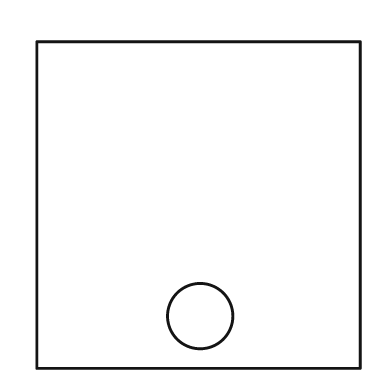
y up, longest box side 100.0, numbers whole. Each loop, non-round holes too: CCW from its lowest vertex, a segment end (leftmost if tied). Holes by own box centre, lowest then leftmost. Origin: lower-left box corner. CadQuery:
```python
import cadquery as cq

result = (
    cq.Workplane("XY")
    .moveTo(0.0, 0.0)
    .lineTo(99.0, 0.0)
    .lineTo(99.0, 100.0)
    .lineTo(0.0, 100.0)
    .close()
    .moveTo(50.0, 16.0)
    .circle(10.0)
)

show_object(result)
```